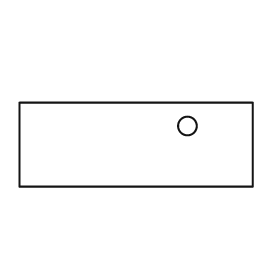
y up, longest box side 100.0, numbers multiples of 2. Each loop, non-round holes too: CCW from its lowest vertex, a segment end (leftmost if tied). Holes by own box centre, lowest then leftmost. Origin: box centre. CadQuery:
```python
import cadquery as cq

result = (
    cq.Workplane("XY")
    .moveTo(-50.0, -18.0)
    .lineTo(50.0, -18.0)
    .lineTo(50.0, 18.0)
    .lineTo(-50.0, 18.0)
    .close()
    .moveTo(22.0, 8.0)
    .circle(4.0)
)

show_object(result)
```